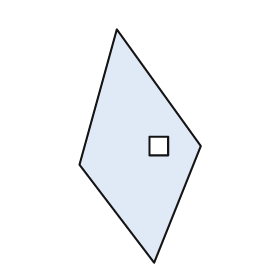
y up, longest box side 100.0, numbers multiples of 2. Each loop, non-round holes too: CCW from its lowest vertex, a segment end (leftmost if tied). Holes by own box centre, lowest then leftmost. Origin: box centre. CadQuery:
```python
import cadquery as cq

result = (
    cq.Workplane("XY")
    .moveTo(6.0, -50.0)
    .lineTo(26.0, 0.0)
    .lineTo(-10.0, 50.0)
    .lineTo(-26.0, -8.0)
    .close()
    .moveTo(4.0, -4.0)
    .lineTo(12.0, -4.0)
    .lineTo(12.0, 4.0)
    .lineTo(4.0, 4.0)
    .close()
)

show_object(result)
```